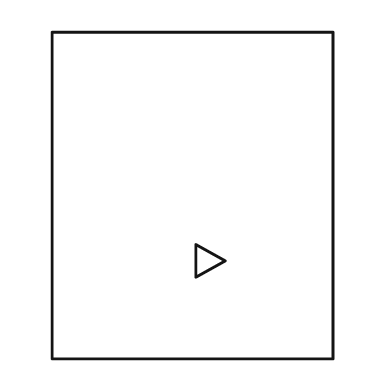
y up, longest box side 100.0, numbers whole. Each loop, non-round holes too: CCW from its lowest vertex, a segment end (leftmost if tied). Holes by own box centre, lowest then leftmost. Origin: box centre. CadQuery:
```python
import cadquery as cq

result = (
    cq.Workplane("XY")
    .moveTo(-43.0, -50.0)
    .lineTo(43.0, -50.0)
    .lineTo(43.0, 50.0)
    .lineTo(-43.0, 50.0)
    .close()
    .moveTo(1.0, -25.0)
    .lineTo(10.0, -20.0)
    .lineTo(1.0, -15.0)
    .close()
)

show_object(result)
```